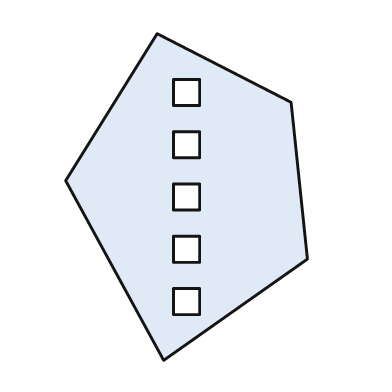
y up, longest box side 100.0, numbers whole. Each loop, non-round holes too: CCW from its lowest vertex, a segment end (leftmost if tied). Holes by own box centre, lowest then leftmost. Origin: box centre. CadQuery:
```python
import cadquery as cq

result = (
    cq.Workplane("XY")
    .moveTo(-7.0, -50.0)
    .lineTo(37.0, -19.0)
    .lineTo(32.0, 29.0)
    .lineTo(-9.0, 50.0)
    .lineTo(-37.0, 5.0)
    .close()
    .moveTo(-4.0, -36.0)
    .lineTo(4.0, -36.0)
    .lineTo(4.0, -28.0)
    .lineTo(-4.0, -28.0)
    .close()
    .moveTo(-4.0, -20.0)
    .lineTo(4.0, -20.0)
    .lineTo(4.0, -12.0)
    .lineTo(-4.0, -12.0)
    .close()
    .moveTo(-4.0, -4.0)
    .lineTo(4.0, -4.0)
    .lineTo(4.0, 4.0)
    .lineTo(-4.0, 4.0)
    .close()
    .moveTo(-4.0, 12.0)
    .lineTo(4.0, 12.0)
    .lineTo(4.0, 20.0)
    .lineTo(-4.0, 20.0)
    .close()
    .moveTo(-4.0, 28.0)
    .lineTo(4.0, 28.0)
    .lineTo(4.0, 36.0)
    .lineTo(-4.0, 36.0)
    .close()
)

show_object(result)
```